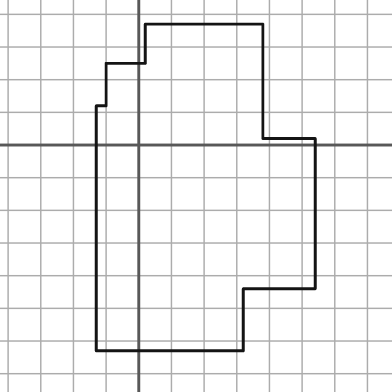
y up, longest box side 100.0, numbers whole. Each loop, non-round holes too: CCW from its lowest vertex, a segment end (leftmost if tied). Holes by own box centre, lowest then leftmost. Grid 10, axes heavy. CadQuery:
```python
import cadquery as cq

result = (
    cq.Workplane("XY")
    .moveTo(-13.0, -63.0)
    .lineTo(32.0, -63.0)
    .lineTo(32.0, -44.0)
    .lineTo(54.0, -44.0)
    .lineTo(54.0, 2.0)
    .lineTo(38.0, 2.0)
    .lineTo(38.0, 37.0)
    .lineTo(2.0, 37.0)
    .lineTo(2.0, 25.0)
    .lineTo(-10.0, 25.0)
    .lineTo(-10.0, 12.0)
    .lineTo(-13.0, 12.0)
    .close()
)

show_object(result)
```